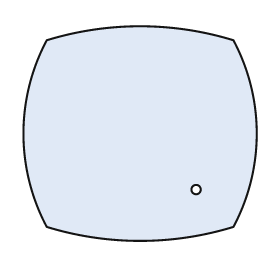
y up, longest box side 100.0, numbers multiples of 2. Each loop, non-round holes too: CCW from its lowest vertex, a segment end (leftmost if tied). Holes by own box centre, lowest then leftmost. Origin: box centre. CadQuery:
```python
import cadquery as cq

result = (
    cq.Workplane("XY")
    .moveTo(-40.0, -40.0)
    .threePointArc((0.0, -46.0), (40.0, -40.0))
    .threePointArc((50.0, 0.0), (40.0, 40.0))
    .threePointArc((0.0, 46.0), (-40.0, 40.0))
    .threePointArc((-50.0, 0.0), (-40.0, -40.0))
    .close()
    .moveTo(24.0, -24.0)
    .circle(2.0)
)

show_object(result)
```